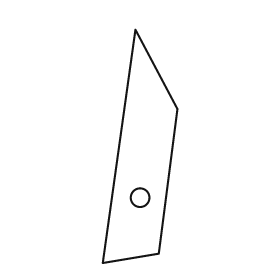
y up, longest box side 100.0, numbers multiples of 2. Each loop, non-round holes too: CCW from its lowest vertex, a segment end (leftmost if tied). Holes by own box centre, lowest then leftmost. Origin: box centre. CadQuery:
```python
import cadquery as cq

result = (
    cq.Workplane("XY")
    .moveTo(-16.0, -50.0)
    .lineTo(8.0, -46.0)
    .lineTo(16.0, 16.0)
    .lineTo(-2.0, 50.0)
    .close()
    .moveTo(0.0, -22.0)
    .circle(4.0)
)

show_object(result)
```